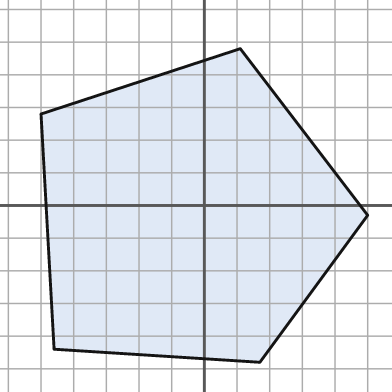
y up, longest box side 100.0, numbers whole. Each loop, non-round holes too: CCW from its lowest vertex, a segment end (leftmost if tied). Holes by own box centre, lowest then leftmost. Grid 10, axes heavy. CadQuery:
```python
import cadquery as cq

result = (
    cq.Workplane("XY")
    .moveTo(17.0, -48.0)
    .lineTo(50.0, -3.0)
    .lineTo(11.0, 48.0)
    .lineTo(-50.0, 28.0)
    .lineTo(-46.0, -44.0)
    .close()
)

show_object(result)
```